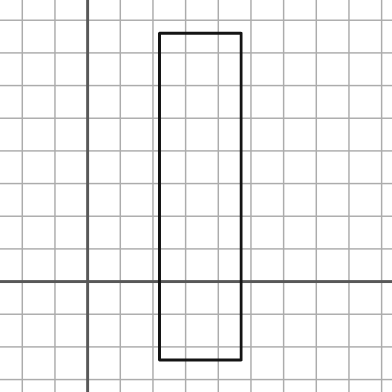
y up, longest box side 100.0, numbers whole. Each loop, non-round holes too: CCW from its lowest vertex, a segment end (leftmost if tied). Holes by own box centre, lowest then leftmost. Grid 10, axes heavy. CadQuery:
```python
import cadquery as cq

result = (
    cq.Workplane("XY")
    .moveTo(22.0, -24.0)
    .lineTo(47.0, -24.0)
    .lineTo(47.0, 76.0)
    .lineTo(22.0, 76.0)
    .close()
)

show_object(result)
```